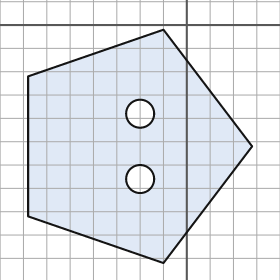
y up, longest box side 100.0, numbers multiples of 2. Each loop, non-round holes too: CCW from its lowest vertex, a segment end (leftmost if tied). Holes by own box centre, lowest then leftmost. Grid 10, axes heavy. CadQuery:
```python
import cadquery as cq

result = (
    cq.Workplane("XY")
    .moveTo(-10.0, -102.0)
    .lineTo(28.0, -52.0)
    .lineTo(-10.0, -2.0)
    .lineTo(-68.0, -22.0)
    .lineTo(-68.0, -82.0)
    .close()
    .moveTo(-20.0, -66.0)
    .circle(6.0)
    .moveTo(-20.0, -38.0)
    .circle(6.0)
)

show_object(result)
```